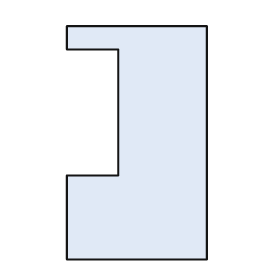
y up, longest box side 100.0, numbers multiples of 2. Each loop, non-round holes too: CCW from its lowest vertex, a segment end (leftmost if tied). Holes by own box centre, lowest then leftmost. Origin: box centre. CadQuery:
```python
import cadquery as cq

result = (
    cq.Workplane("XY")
    .moveTo(-30.0, -50.0)
    .lineTo(30.0, -50.0)
    .lineTo(30.0, 50.0)
    .lineTo(-30.0, 50.0)
    .lineTo(-30.0, 40.0)
    .lineTo(-8.0, 40.0)
    .lineTo(-8.0, -14.0)
    .lineTo(-30.0, -14.0)
    .close()
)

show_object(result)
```